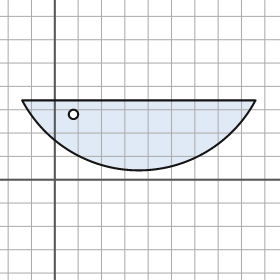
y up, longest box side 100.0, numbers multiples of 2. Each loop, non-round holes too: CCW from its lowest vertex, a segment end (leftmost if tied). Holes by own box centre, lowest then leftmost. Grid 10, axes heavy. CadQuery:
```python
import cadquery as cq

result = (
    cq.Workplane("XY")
    .moveTo(-14.0, 34.0)
    .threePointArc((36.0, 4.0), (86.0, 34.0))
    .close()
    .moveTo(8.0, 28.0)
    .circle(2.0)
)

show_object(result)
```